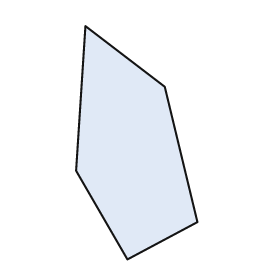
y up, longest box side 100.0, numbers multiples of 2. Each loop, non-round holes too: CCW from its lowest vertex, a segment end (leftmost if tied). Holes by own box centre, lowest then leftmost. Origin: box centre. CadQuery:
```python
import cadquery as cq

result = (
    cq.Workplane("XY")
    .moveTo(-4.0, -50.0)
    .lineTo(26.0, -34.0)
    .lineTo(12.0, 24.0)
    .lineTo(-22.0, 50.0)
    .lineTo(-26.0, -12.0)
    .close()
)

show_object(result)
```